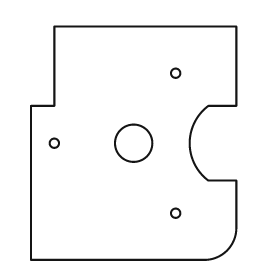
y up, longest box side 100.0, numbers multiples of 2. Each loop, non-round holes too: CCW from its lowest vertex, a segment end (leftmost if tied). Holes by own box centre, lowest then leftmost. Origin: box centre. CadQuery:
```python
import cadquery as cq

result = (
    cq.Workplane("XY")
    .moveTo(-44.0, -50.0)
    .lineTo(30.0, -50.0)
    .threePointArc((40.0, -46.0), (44.0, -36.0))
    .lineTo(44.0, -16.0)
    .lineTo(32.0, -16.0)
    .threePointArc((24.0, 0.0), (32.0, 16.0))
    .lineTo(44.0, 16.0)
    .lineTo(44.0, 50.0)
    .lineTo(-34.0, 50.0)
    .lineTo(-34.0, 16.0)
    .lineTo(-44.0, 16.0)
    .close()
    .moveTo(18.0, -30.0)
    .circle(2.0)
    .moveTo(-34.0, 0.0)
    .circle(2.0)
    .moveTo(0.0, 0.0)
    .circle(8.0)
    .moveTo(18.0, 30.0)
    .circle(2.0)
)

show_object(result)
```